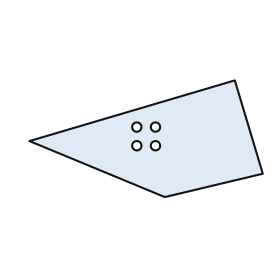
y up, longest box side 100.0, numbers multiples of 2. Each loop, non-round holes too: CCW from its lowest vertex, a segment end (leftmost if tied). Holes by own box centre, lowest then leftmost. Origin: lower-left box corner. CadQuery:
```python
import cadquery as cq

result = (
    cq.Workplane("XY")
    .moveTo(58.0, 0.0)
    .lineTo(100.0, 10.0)
    .lineTo(88.0, 50.0)
    .lineTo(0.0, 24.0)
    .close()
    .moveTo(46.0, 22.0)
    .circle(2.0)
    .moveTo(54.0, 22.0)
    .circle(2.0)
    .moveTo(46.0, 30.0)
    .circle(2.0)
    .moveTo(54.0, 30.0)
    .circle(2.0)
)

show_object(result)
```